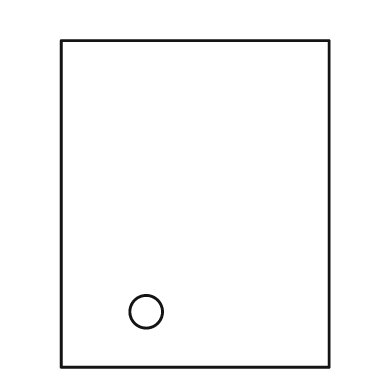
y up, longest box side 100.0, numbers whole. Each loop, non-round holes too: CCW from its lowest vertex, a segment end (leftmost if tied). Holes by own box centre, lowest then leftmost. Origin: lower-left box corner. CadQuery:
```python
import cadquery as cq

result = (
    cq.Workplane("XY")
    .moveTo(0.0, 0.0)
    .lineTo(82.0, 0.0)
    .lineTo(82.0, 100.0)
    .lineTo(0.0, 100.0)
    .close()
    .moveTo(26.0, 17.0)
    .circle(5.0)
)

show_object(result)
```